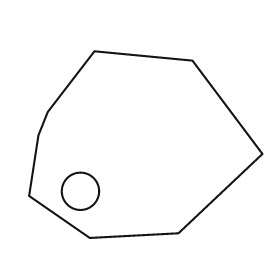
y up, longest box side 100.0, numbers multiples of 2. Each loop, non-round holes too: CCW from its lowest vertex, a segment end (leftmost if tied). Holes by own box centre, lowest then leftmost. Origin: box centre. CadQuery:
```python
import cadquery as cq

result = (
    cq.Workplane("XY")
    .moveTo(-24.0, -40.0)
    .lineTo(14.0, -38.0)
    .lineTo(50.0, -4.0)
    .lineTo(20.0, 36.0)
    .lineTo(-22.0, 40.0)
    .lineTo(-42.0, 14.0)
    .lineTo(-46.0, 4.0)
    .lineTo(-50.0, -22.0)
    .close()
    .moveTo(-28.0, -20.0)
    .circle(8.0)
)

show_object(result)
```